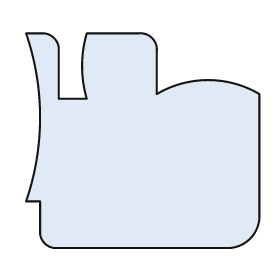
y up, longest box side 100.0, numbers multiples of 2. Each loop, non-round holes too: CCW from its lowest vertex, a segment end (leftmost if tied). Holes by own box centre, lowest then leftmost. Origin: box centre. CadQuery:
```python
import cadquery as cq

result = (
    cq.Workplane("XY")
    .moveTo(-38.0, -46.0)
    .lineTo(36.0, -46.0)
    .threePointArc((46.0, -42.0), (50.0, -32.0))
    .lineTo(50.0, 20.0)
    .threePointArc((28.0, 26.0), (6.0, 20.0))
    .lineTo(6.0, 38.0)
    .threePointArc((4.0, 44.0), (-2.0, 46.0))
    .lineTo(-24.0, 46.0)
    .threePointArc((-26.0, 32.0), (-24.0, 18.0))
    .lineTo(-36.0, 18.0)
    .lineTo(-36.0, 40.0)
    .threePointArc((-38.0, 44.0), (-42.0, 46.0))
    .lineTo(-50.0, 46.0)
    .threePointArc((-44.0, 10.0), (-50.0, -26.0))
    .lineTo(-44.0, -26.0)
    .lineTo(-44.0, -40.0)
    .threePointArc((-42.0, -44.0), (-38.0, -46.0))
    .close()
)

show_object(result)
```